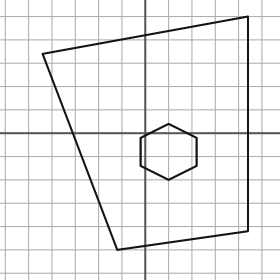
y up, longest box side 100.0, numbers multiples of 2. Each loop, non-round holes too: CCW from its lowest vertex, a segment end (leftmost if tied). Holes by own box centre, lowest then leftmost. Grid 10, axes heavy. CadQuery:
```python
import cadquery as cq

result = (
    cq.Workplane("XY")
    .moveTo(-12.0, -50.0)
    .lineTo(44.0, -42.0)
    .lineTo(44.0, 50.0)
    .lineTo(-44.0, 34.0)
    .close()
    .moveTo(10.0, -20.0)
    .lineTo(22.0, -14.0)
    .lineTo(22.0, -2.0)
    .lineTo(10.0, 4.0)
    .lineTo(-2.0, -2.0)
    .lineTo(-2.0, -14.0)
    .close()
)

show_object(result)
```